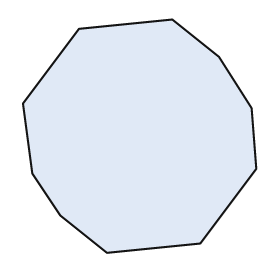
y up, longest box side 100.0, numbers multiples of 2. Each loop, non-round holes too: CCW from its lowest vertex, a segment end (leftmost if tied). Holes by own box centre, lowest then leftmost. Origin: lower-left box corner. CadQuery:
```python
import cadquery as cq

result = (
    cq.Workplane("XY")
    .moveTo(36.0, 0.0)
    .lineTo(76.0, 4.0)
    .lineTo(100.0, 36.0)
    .lineTo(98.0, 62.0)
    .lineTo(84.0, 84.0)
    .lineTo(64.0, 100.0)
    .lineTo(24.0, 96.0)
    .lineTo(0.0, 64.0)
    .lineTo(4.0, 34.0)
    .lineTo(16.0, 16.0)
    .close()
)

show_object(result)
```